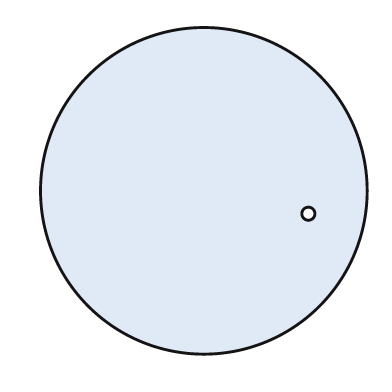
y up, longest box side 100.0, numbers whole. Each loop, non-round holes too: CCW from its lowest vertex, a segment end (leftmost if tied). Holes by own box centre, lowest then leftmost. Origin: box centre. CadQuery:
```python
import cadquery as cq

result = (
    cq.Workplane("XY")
    .moveTo(0.0, 0.0)
    .circle(50.0)
    .moveTo(32.0, -7.0)
    .circle(2.0)
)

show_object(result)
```